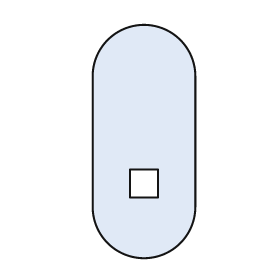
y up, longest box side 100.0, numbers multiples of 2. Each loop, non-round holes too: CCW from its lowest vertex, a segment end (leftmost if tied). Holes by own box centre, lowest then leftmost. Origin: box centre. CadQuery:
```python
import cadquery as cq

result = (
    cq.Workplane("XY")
    .moveTo(-22.0, -28.0)
    .threePointArc((0.0, -50.0), (22.0, -28.0))
    .lineTo(22.0, 28.0)
    .threePointArc((0.0, 50.0), (-22.0, 28.0))
    .close()
    .moveTo(-6.0, -24.0)
    .lineTo(6.0, -24.0)
    .lineTo(6.0, -12.0)
    .lineTo(-6.0, -12.0)
    .close()
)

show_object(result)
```